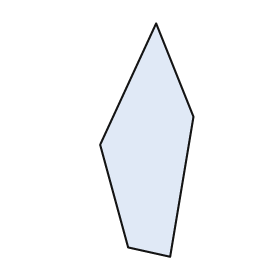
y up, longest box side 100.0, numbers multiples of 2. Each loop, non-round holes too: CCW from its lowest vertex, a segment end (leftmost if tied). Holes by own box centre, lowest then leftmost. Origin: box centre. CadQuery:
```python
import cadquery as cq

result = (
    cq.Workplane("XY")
    .moveTo(10.0, -50.0)
    .lineTo(20.0, 10.0)
    .lineTo(4.0, 50.0)
    .lineTo(-20.0, -2.0)
    .lineTo(-8.0, -46.0)
    .close()
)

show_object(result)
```